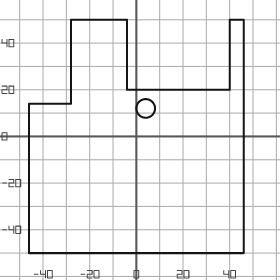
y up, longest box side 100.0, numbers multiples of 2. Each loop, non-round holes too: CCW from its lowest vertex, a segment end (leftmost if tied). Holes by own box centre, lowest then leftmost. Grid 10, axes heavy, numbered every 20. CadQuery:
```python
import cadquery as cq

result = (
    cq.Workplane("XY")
    .moveTo(-46.0, -50.0)
    .lineTo(46.0, -50.0)
    .lineTo(46.0, 50.0)
    .lineTo(40.0, 50.0)
    .lineTo(40.0, 20.0)
    .lineTo(-4.0, 20.0)
    .lineTo(-4.0, 50.0)
    .lineTo(-28.0, 50.0)
    .lineTo(-28.0, 14.0)
    .lineTo(-46.0, 14.0)
    .close()
    .moveTo(4.0, 12.0)
    .circle(4.0)
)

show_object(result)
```